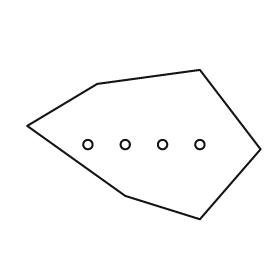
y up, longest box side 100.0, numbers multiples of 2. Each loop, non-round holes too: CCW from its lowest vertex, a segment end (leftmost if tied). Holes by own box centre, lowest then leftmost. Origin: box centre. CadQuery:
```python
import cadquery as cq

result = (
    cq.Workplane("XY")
    .moveTo(24.0, -32.0)
    .lineTo(50.0, -2.0)
    .lineTo(24.0, 32.0)
    .lineTo(-20.0, 26.0)
    .lineTo(-50.0, 8.0)
    .lineTo(-8.0, -22.0)
    .close()
    .moveTo(-24.0, 0.0)
    .circle(2.0)
    .moveTo(-8.0, 0.0)
    .circle(2.0)
    .moveTo(8.0, 0.0)
    .circle(2.0)
    .moveTo(24.0, 0.0)
    .circle(2.0)
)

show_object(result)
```